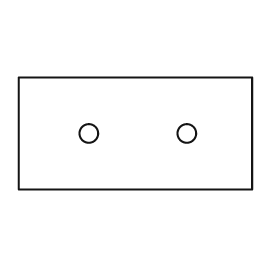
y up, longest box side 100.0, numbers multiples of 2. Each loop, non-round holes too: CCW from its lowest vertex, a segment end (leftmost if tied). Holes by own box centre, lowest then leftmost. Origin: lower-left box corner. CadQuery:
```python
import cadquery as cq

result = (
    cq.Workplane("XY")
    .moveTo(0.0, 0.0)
    .lineTo(100.0, 0.0)
    .lineTo(100.0, 48.0)
    .lineTo(0.0, 48.0)
    .close()
    .moveTo(30.0, 24.0)
    .circle(4.0)
    .moveTo(72.0, 24.0)
    .circle(4.0)
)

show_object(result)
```